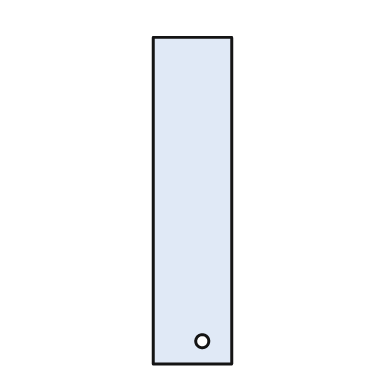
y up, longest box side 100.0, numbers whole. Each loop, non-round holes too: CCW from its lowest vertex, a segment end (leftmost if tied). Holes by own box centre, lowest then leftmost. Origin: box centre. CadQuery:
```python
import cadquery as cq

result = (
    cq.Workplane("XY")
    .moveTo(-12.0, -50.0)
    .lineTo(12.0, -50.0)
    .lineTo(12.0, 50.0)
    .lineTo(-12.0, 50.0)
    .close()
    .moveTo(3.0, -43.0)
    .circle(2.0)
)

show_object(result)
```